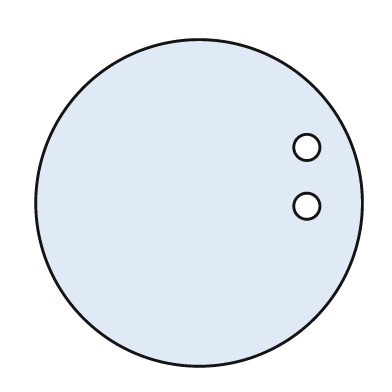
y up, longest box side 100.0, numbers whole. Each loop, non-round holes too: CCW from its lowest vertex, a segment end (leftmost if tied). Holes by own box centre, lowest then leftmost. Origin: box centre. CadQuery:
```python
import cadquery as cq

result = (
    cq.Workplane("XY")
    .moveTo(0.0, 0.0)
    .circle(50.0)
    .moveTo(33.0, -1.0)
    .circle(4.0)
    .moveTo(33.0, 17.0)
    .circle(4.0)
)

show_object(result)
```